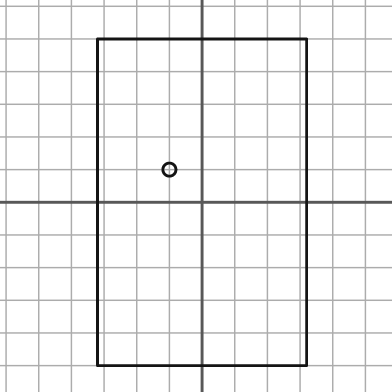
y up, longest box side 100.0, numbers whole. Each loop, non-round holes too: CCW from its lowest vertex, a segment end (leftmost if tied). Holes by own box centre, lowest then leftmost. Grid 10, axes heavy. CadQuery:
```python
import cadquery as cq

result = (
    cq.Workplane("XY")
    .moveTo(-32.0, -50.0)
    .lineTo(32.0, -50.0)
    .lineTo(32.0, 50.0)
    .lineTo(-32.0, 50.0)
    .close()
    .moveTo(-10.0, 10.0)
    .circle(2.0)
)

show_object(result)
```